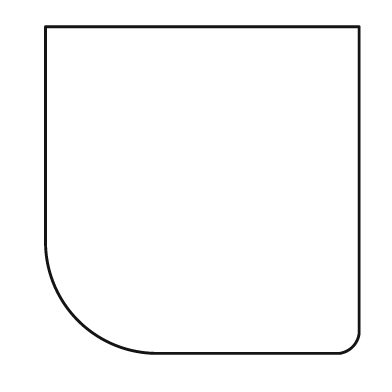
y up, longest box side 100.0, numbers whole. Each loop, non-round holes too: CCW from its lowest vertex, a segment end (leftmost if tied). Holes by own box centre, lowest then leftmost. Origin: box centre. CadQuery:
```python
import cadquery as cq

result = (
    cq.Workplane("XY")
    .moveTo(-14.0, -50.0)
    .lineTo(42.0, -50.0)
    .threePointArc((46.0, -48.0), (48.0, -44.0))
    .lineTo(48.0, 50.0)
    .lineTo(-48.0, 50.0)
    .lineTo(-48.0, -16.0)
    .threePointArc((-38.0, -40.0), (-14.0, -50.0))
    .close()
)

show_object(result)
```